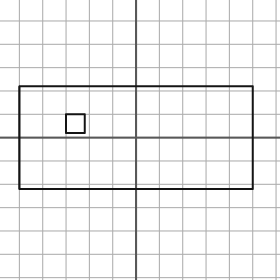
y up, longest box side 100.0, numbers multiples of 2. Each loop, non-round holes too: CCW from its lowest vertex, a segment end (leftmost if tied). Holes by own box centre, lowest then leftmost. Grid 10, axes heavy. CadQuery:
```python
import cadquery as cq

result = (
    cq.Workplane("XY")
    .moveTo(-50.0, -22.0)
    .lineTo(50.0, -22.0)
    .lineTo(50.0, 22.0)
    .lineTo(-50.0, 22.0)
    .close()
    .moveTo(-30.0, 2.0)
    .lineTo(-22.0, 2.0)
    .lineTo(-22.0, 10.0)
    .lineTo(-30.0, 10.0)
    .close()
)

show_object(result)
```